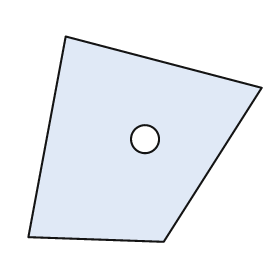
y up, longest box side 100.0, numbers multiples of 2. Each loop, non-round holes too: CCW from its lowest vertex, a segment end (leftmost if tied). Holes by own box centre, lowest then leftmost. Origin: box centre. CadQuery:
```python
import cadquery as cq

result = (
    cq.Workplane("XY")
    .moveTo(8.0, -44.0)
    .lineTo(50.0, 22.0)
    .lineTo(-34.0, 44.0)
    .lineTo(-50.0, -42.0)
    .close()
    .moveTo(0.0, 0.0)
    .circle(6.0)
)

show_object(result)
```